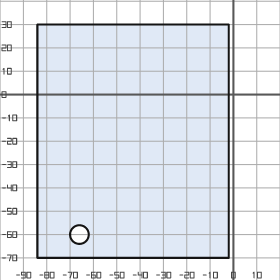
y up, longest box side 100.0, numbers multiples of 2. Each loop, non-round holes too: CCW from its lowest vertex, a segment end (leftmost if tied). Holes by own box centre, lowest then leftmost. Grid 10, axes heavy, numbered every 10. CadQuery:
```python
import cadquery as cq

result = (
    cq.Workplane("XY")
    .moveTo(-84.0, -70.0)
    .lineTo(-2.0, -70.0)
    .lineTo(-2.0, 30.0)
    .lineTo(-84.0, 30.0)
    .close()
    .moveTo(-66.0, -60.0)
    .circle(4.0)
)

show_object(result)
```